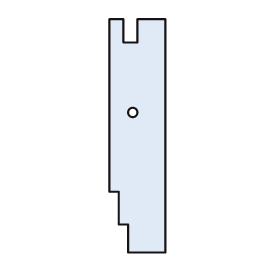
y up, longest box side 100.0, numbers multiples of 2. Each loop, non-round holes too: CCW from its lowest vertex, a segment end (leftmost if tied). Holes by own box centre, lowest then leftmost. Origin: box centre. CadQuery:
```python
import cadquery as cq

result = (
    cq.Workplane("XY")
    .moveTo(-4.0, -50.0)
    .lineTo(12.0, -50.0)
    .lineTo(12.0, 50.0)
    .lineTo(0.0, 50.0)
    .lineTo(0.0, 40.0)
    .lineTo(-6.0, 40.0)
    .lineTo(-6.0, 50.0)
    .lineTo(-12.0, 50.0)
    .lineTo(-12.0, -24.0)
    .lineTo(-8.0, -24.0)
    .lineTo(-8.0, -38.0)
    .lineTo(-4.0, -38.0)
    .close()
    .moveTo(-2.0, 10.0)
    .circle(2.0)
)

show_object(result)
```